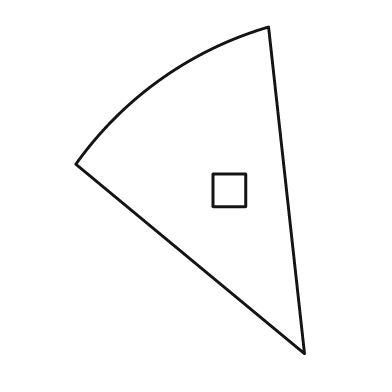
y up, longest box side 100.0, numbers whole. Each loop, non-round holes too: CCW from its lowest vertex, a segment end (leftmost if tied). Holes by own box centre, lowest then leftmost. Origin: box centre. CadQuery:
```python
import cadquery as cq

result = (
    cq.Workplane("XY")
    .moveTo(35.0, -50.0)
    .lineTo(24.0, 50.0)
    .threePointArc((-9.0, 34.0), (-35.0, 8.0))
    .close()
    .moveTo(7.0, -5.0)
    .lineTo(17.0, -5.0)
    .lineTo(17.0, 5.0)
    .lineTo(7.0, 5.0)
    .close()
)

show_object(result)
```